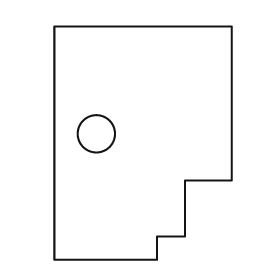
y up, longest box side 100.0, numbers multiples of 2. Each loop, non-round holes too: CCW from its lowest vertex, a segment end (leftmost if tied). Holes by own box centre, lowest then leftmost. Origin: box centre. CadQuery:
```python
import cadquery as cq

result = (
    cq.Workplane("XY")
    .moveTo(-38.0, -50.0)
    .lineTo(6.0, -50.0)
    .lineTo(6.0, -40.0)
    .lineTo(18.0, -40.0)
    .lineTo(18.0, -16.0)
    .lineTo(38.0, -16.0)
    .lineTo(38.0, 50.0)
    .lineTo(-38.0, 50.0)
    .close()
    .moveTo(-20.0, 4.0)
    .circle(8.0)
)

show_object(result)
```